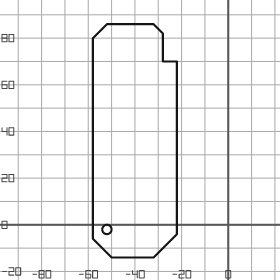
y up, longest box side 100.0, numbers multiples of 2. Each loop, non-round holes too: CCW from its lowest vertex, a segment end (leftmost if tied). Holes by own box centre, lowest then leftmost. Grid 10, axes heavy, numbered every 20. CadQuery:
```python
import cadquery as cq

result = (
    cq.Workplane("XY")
    .moveTo(-50.0, -14.0)
    .lineTo(-32.0, -14.0)
    .lineTo(-22.0, -4.0)
    .lineTo(-22.0, 70.0)
    .lineTo(-28.0, 70.0)
    .lineTo(-28.0, 82.0)
    .lineTo(-32.0, 86.0)
    .lineTo(-52.0, 86.0)
    .lineTo(-58.0, 80.0)
    .lineTo(-58.0, -6.0)
    .close()
    .moveTo(-52.0, -2.0)
    .circle(2.0)
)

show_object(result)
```